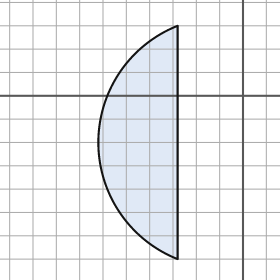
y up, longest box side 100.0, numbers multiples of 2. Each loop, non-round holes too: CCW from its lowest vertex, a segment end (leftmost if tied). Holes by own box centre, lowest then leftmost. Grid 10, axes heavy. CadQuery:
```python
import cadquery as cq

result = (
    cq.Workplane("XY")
    .moveTo(-28.0, -70.0)
    .lineTo(-28.0, 30.0)
    .threePointArc((-62.0, -20.0), (-28.0, -70.0))
    .close()
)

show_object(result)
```